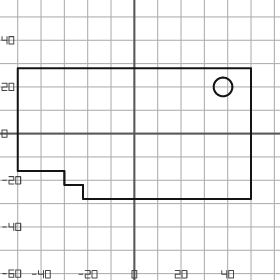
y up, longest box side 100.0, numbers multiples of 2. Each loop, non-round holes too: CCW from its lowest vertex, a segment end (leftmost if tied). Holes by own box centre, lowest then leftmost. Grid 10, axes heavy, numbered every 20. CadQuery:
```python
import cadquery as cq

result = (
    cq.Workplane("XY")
    .moveTo(-22.0, -28.0)
    .lineTo(50.0, -28.0)
    .lineTo(50.0, 28.0)
    .lineTo(-50.0, 28.0)
    .lineTo(-50.0, -16.0)
    .lineTo(-30.0, -16.0)
    .lineTo(-30.0, -22.0)
    .lineTo(-22.0, -22.0)
    .close()
    .moveTo(38.0, 20.0)
    .circle(4.0)
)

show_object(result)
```